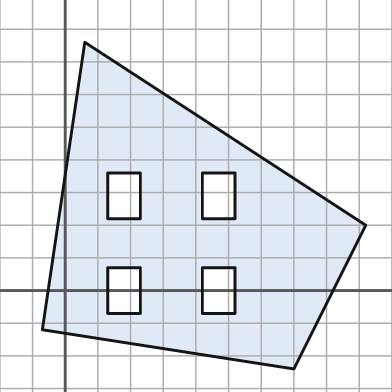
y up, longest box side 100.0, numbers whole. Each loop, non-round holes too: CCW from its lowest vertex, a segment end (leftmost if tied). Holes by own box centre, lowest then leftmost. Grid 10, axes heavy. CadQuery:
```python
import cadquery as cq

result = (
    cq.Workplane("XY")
    .moveTo(70.0, -24.0)
    .lineTo(92.0, 20.0)
    .lineTo(6.0, 76.0)
    .lineTo(-7.0, -12.0)
    .close()
    .moveTo(13.0, -7.0)
    .lineTo(23.0, -7.0)
    .lineTo(23.0, 7.0)
    .lineTo(13.0, 7.0)
    .close()
    .moveTo(42.0, -7.0)
    .lineTo(52.0, -7.0)
    .lineTo(52.0, 7.0)
    .lineTo(42.0, 7.0)
    .close()
    .moveTo(13.0, 22.0)
    .lineTo(23.0, 22.0)
    .lineTo(23.0, 36.0)
    .lineTo(13.0, 36.0)
    .close()
    .moveTo(42.0, 22.0)
    .lineTo(52.0, 22.0)
    .lineTo(52.0, 36.0)
    .lineTo(42.0, 36.0)
    .close()
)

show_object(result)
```